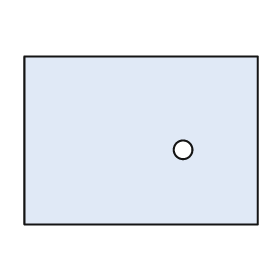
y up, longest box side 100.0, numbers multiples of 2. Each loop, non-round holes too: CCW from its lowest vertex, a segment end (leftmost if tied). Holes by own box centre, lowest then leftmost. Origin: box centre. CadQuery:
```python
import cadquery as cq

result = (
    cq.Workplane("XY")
    .moveTo(-50.0, -36.0)
    .lineTo(50.0, -36.0)
    .lineTo(50.0, 36.0)
    .lineTo(-50.0, 36.0)
    .close()
    .moveTo(18.0, -4.0)
    .circle(4.0)
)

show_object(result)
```